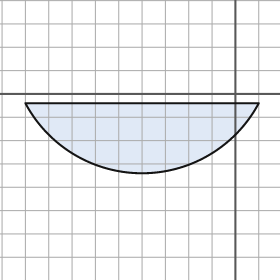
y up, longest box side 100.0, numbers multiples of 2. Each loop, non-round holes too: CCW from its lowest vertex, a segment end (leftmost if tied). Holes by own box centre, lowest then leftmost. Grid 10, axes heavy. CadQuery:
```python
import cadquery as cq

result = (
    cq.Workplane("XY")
    .moveTo(-90.0, -4.0)
    .threePointArc((-40.0, -34.0), (10.0, -4.0))
    .close()
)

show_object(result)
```